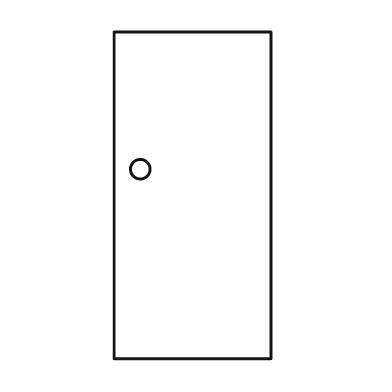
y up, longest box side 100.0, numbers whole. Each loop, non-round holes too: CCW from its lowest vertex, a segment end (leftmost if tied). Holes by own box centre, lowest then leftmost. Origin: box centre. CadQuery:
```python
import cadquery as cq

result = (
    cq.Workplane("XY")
    .moveTo(-24.0, -50.0)
    .lineTo(24.0, -50.0)
    .lineTo(24.0, 50.0)
    .lineTo(-24.0, 50.0)
    .close()
    .moveTo(-16.0, 8.0)
    .circle(3.0)
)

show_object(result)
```